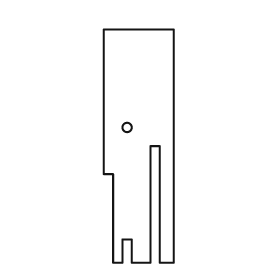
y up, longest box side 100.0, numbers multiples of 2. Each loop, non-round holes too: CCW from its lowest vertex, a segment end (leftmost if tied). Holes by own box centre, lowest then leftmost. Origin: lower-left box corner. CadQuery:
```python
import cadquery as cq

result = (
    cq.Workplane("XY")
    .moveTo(4.0, 0.0)
    .lineTo(8.0, 0.0)
    .lineTo(8.0, 10.0)
    .lineTo(12.0, 10.0)
    .lineTo(12.0, 0.0)
    .lineTo(20.0, 0.0)
    .lineTo(20.0, 50.0)
    .lineTo(24.0, 50.0)
    .lineTo(24.0, 0.0)
    .lineTo(30.0, 0.0)
    .lineTo(30.0, 100.0)
    .lineTo(0.0, 100.0)
    .lineTo(0.0, 38.0)
    .lineTo(4.0, 38.0)
    .close()
    .moveTo(10.0, 58.0)
    .circle(2.0)
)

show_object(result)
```